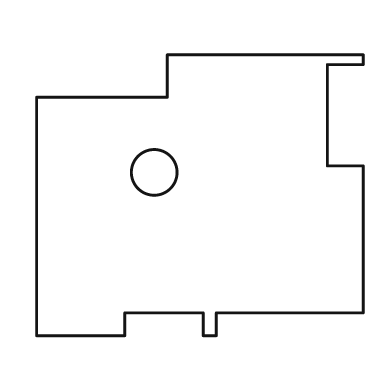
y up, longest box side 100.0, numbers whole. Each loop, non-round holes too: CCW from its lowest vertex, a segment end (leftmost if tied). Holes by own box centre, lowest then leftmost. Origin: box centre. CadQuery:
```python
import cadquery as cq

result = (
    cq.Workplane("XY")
    .moveTo(-50.0, -43.0)
    .lineTo(-23.0, -43.0)
    .lineTo(-23.0, -36.0)
    .lineTo(1.0, -36.0)
    .lineTo(1.0, -43.0)
    .lineTo(5.0, -43.0)
    .lineTo(5.0, -36.0)
    .lineTo(50.0, -36.0)
    .lineTo(50.0, 9.0)
    .lineTo(39.0, 9.0)
    .lineTo(39.0, 40.0)
    .lineTo(50.0, 40.0)
    .lineTo(50.0, 43.0)
    .lineTo(-10.0, 43.0)
    .lineTo(-10.0, 30.0)
    .lineTo(-50.0, 30.0)
    .close()
    .moveTo(-14.0, 7.0)
    .circle(7.0)
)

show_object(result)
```